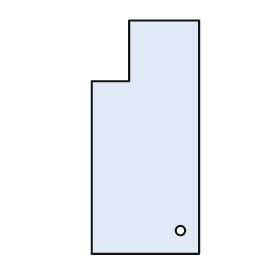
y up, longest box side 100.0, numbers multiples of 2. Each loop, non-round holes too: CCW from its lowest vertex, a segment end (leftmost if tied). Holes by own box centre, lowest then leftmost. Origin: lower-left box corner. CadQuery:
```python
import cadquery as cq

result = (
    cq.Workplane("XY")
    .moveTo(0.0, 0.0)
    .lineTo(46.0, 0.0)
    .lineTo(46.0, 100.0)
    .lineTo(16.0, 100.0)
    .lineTo(16.0, 74.0)
    .lineTo(0.0, 74.0)
    .close()
    .moveTo(38.0, 10.0)
    .circle(2.0)
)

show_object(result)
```